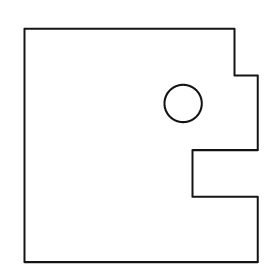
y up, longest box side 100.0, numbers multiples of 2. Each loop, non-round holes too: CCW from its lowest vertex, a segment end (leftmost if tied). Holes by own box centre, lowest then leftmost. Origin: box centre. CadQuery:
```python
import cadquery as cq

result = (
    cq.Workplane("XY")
    .moveTo(-50.0, -50.0)
    .lineTo(50.0, -50.0)
    .lineTo(50.0, -22.0)
    .lineTo(22.0, -22.0)
    .lineTo(22.0, -2.0)
    .lineTo(50.0, -2.0)
    .lineTo(50.0, 30.0)
    .lineTo(40.0, 30.0)
    .lineTo(40.0, 50.0)
    .lineTo(-50.0, 50.0)
    .close()
    .moveTo(18.0, 18.0)
    .circle(8.0)
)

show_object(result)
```